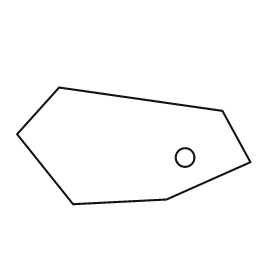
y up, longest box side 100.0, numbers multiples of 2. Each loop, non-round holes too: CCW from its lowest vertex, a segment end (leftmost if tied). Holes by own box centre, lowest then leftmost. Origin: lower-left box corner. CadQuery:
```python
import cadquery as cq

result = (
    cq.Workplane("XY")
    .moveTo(24.0, 0.0)
    .lineTo(64.0, 2.0)
    .lineTo(100.0, 18.0)
    .lineTo(88.0, 40.0)
    .lineTo(18.0, 50.0)
    .lineTo(0.0, 30.0)
    .close()
    .moveTo(72.0, 20.0)
    .circle(4.0)
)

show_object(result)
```